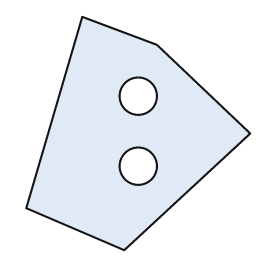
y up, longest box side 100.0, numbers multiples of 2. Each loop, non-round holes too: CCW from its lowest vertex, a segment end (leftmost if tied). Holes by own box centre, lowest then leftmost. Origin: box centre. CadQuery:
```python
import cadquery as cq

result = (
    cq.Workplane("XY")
    .moveTo(-6.0, -50.0)
    .lineTo(48.0, 0.0)
    .lineTo(8.0, 38.0)
    .lineTo(-24.0, 50.0)
    .lineTo(-48.0, -32.0)
    .close()
    .moveTo(0.0, -14.0)
    .circle(8.0)
    .moveTo(0.0, 16.0)
    .circle(8.0)
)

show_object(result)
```